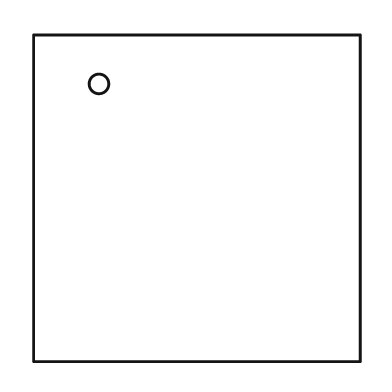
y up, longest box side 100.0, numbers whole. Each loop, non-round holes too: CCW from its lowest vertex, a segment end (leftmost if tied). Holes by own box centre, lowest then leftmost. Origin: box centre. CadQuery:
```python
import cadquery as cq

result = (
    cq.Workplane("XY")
    .moveTo(-50.0, -50.0)
    .lineTo(50.0, -50.0)
    .lineTo(50.0, 50.0)
    .lineTo(-50.0, 50.0)
    .close()
    .moveTo(-30.0, 35.0)
    .circle(3.0)
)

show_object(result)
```